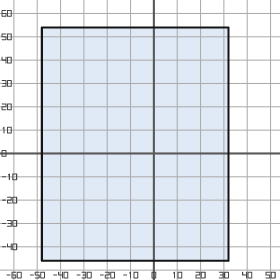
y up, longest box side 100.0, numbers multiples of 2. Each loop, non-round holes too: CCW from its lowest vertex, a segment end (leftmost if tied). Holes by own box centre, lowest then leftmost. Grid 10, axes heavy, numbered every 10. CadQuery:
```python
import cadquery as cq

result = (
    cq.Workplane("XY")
    .moveTo(-48.0, -46.0)
    .lineTo(32.0, -46.0)
    .lineTo(32.0, 54.0)
    .lineTo(-48.0, 54.0)
    .close()
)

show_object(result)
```